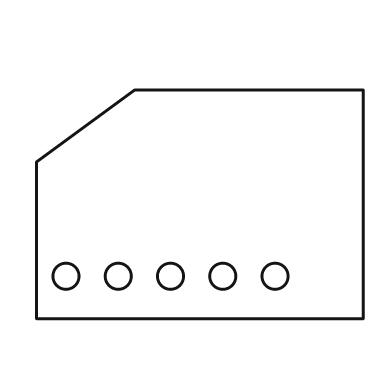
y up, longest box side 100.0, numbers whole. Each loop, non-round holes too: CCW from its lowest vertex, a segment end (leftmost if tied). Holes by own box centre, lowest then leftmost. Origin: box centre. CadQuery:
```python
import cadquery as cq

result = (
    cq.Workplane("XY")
    .moveTo(-50.0, -35.0)
    .lineTo(50.0, -35.0)
    .lineTo(50.0, 35.0)
    .lineTo(-20.0, 35.0)
    .lineTo(-50.0, 13.0)
    .close()
    .moveTo(-41.0, -22.0)
    .circle(4.0)
    .moveTo(-25.0, -22.0)
    .circle(4.0)
    .moveTo(-9.0, -22.0)
    .circle(4.0)
    .moveTo(7.0, -22.0)
    .circle(4.0)
    .moveTo(23.0, -22.0)
    .circle(4.0)
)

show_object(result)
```